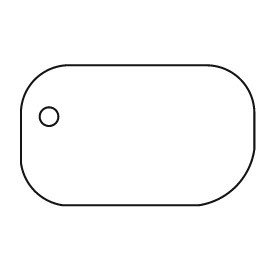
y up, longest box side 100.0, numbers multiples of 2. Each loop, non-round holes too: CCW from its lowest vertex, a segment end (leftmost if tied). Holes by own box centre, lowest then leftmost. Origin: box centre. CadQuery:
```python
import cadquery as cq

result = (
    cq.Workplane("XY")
    .moveTo(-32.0, -30.0)
    .lineTo(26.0, -30.0)
    .threePointArc((42.0, -22.0), (50.0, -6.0))
    .lineTo(50.0, 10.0)
    .threePointArc((44.0, 24.0), (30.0, 30.0))
    .lineTo(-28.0, 30.0)
    .threePointArc((-44.0, 24.0), (-50.0, 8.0))
    .lineTo(-50.0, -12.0)
    .threePointArc((-44.0, -24.0), (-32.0, -30.0))
    .close()
    .moveTo(-38.0, 8.0)
    .circle(4.0)
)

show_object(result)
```